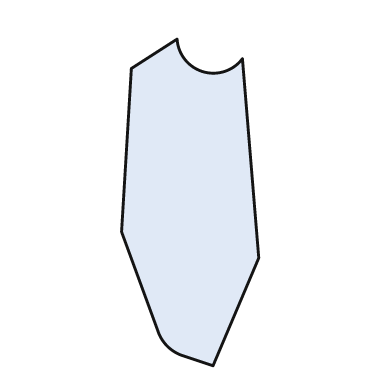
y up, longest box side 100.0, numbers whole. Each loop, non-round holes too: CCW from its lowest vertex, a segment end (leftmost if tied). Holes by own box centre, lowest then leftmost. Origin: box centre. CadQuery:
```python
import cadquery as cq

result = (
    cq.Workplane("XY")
    .moveTo(7.0, -50.0)
    .lineTo(21.0, -17.0)
    .lineTo(16.0, 44.0)
    .threePointArc((4.0, 40.0), (-4.0, 50.0))
    .lineTo(-18.0, 41.0)
    .lineTo(-21.0, -9.0)
    .lineTo(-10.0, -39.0)
    .threePointArc((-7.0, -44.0), (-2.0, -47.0))
    .close()
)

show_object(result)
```